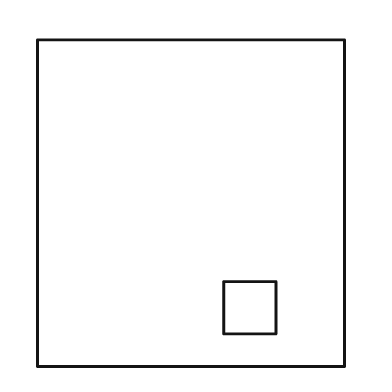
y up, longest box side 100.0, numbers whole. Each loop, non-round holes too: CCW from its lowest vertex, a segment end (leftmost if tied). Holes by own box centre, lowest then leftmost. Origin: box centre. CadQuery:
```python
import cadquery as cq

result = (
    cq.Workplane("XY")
    .moveTo(-47.0, -50.0)
    .lineTo(47.0, -50.0)
    .lineTo(47.0, 50.0)
    .lineTo(-47.0, 50.0)
    .close()
    .moveTo(10.0, -40.0)
    .lineTo(26.0, -40.0)
    .lineTo(26.0, -24.0)
    .lineTo(10.0, -24.0)
    .close()
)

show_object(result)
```